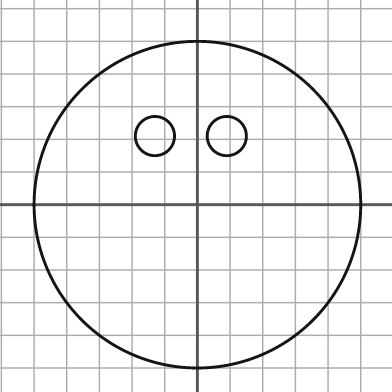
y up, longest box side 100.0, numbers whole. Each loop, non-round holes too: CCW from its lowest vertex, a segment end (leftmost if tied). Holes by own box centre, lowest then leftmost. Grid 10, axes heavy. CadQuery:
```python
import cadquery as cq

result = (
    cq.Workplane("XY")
    .moveTo(0.0, 0.0)
    .circle(50.0)
    .moveTo(-13.0, 21.0)
    .circle(6.0)
    .moveTo(9.0, 21.0)
    .circle(6.0)
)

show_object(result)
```